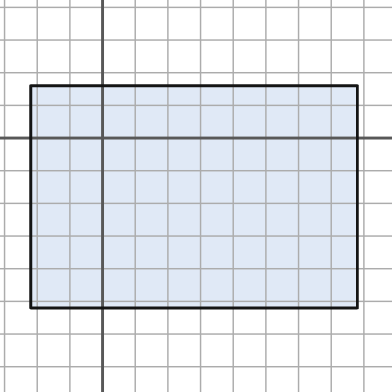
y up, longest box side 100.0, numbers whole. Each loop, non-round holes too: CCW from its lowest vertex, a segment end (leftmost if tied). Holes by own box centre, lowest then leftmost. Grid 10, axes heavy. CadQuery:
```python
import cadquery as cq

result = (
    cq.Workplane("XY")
    .moveTo(-22.0, -52.0)
    .lineTo(78.0, -52.0)
    .lineTo(78.0, 16.0)
    .lineTo(-22.0, 16.0)
    .close()
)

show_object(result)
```